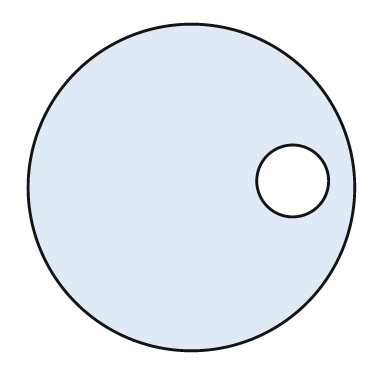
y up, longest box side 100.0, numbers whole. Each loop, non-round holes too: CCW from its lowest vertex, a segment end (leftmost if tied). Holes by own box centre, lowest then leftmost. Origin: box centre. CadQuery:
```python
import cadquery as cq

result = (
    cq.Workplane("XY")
    .moveTo(0.0, 0.0)
    .circle(50.0)
    .moveTo(31.0, 2.0)
    .circle(11.0)
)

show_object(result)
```